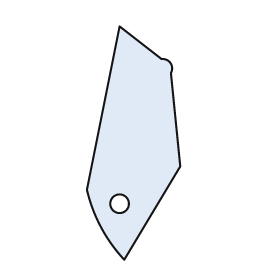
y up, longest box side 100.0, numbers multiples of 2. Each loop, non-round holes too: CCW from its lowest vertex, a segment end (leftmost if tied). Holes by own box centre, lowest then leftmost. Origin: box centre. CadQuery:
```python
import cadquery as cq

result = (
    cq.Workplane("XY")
    .moveTo(-4.0, -50.0)
    .lineTo(20.0, -10.0)
    .lineTo(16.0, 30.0)
    .threePointArc((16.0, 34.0), (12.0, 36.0))
    .lineTo(-6.0, 50.0)
    .lineTo(-20.0, -20.0)
    .threePointArc((-14.0, -36.0), (-4.0, -50.0))
    .close()
    .moveTo(-6.0, -26.0)
    .circle(4.0)
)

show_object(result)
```